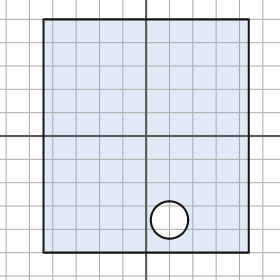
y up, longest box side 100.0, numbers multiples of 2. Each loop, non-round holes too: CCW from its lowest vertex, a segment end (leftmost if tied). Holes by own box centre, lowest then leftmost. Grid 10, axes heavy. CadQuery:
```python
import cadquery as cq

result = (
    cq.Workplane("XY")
    .moveTo(-44.0, -50.0)
    .lineTo(44.0, -50.0)
    .lineTo(44.0, 50.0)
    .lineTo(-44.0, 50.0)
    .close()
    .moveTo(10.0, -36.0)
    .circle(8.0)
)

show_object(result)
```